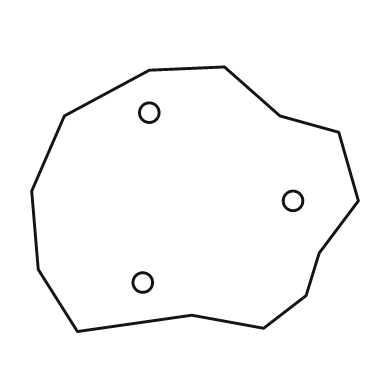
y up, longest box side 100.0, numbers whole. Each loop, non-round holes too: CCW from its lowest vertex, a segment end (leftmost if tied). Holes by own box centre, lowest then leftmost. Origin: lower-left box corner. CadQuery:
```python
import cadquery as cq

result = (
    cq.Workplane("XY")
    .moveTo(14.0, 0.0)
    .lineTo(49.0, 5.0)
    .lineTo(71.0, 1.0)
    .lineTo(84.0, 11.0)
    .lineTo(88.0, 24.0)
    .lineTo(100.0, 40.0)
    .lineTo(94.0, 61.0)
    .lineTo(76.0, 66.0)
    .lineTo(59.0, 81.0)
    .lineTo(36.0, 80.0)
    .lineTo(10.0, 66.0)
    .lineTo(0.0, 43.0)
    .lineTo(2.0, 19.0)
    .close()
    .moveTo(34.0, 15.0)
    .circle(3.0)
    .moveTo(80.0, 40.0)
    .circle(3.0)
    .moveTo(36.0, 67.0)
    .circle(3.0)
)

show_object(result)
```